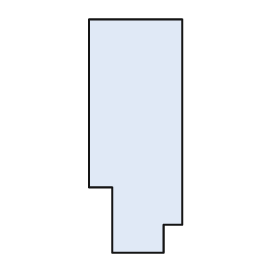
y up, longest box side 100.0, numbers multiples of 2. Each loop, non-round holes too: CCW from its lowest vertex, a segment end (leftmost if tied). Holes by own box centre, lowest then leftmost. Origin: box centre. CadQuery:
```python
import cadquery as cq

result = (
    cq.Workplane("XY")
    .moveTo(-10.0, -50.0)
    .lineTo(12.0, -50.0)
    .lineTo(12.0, -38.0)
    .lineTo(20.0, -38.0)
    .lineTo(20.0, 50.0)
    .lineTo(-20.0, 50.0)
    .lineTo(-20.0, -22.0)
    .lineTo(-10.0, -22.0)
    .close()
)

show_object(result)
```